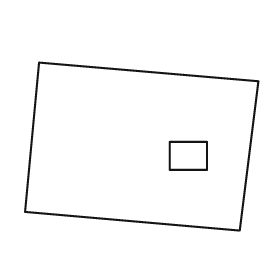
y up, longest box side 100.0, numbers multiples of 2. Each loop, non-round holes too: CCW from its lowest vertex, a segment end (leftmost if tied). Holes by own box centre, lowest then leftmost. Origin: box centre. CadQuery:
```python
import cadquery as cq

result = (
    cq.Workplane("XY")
    .moveTo(42.0, -36.0)
    .lineTo(50.0, 28.0)
    .lineTo(-44.0, 36.0)
    .lineTo(-50.0, -28.0)
    .close()
    .moveTo(12.0, -10.0)
    .lineTo(28.0, -10.0)
    .lineTo(28.0, 2.0)
    .lineTo(12.0, 2.0)
    .close()
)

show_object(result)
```